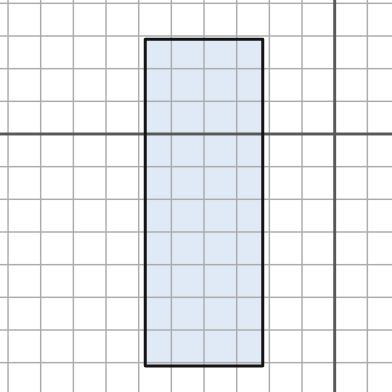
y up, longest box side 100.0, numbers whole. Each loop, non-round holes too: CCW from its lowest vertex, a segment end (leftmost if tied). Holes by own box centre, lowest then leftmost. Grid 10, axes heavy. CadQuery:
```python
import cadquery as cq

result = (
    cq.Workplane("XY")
    .moveTo(-58.0, -71.0)
    .lineTo(-22.0, -71.0)
    .lineTo(-22.0, 29.0)
    .lineTo(-58.0, 29.0)
    .close()
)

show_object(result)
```